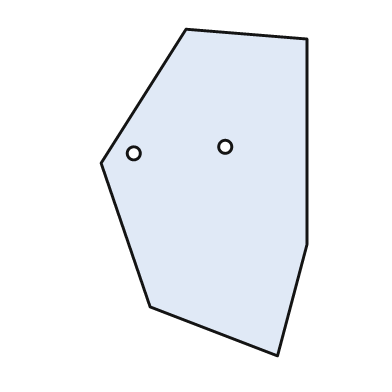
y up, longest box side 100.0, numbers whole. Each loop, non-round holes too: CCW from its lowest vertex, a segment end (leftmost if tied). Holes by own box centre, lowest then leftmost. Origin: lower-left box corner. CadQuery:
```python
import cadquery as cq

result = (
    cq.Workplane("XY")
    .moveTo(54.0, 0.0)
    .lineTo(63.0, 34.0)
    .lineTo(63.0, 97.0)
    .lineTo(26.0, 100.0)
    .lineTo(0.0, 59.0)
    .lineTo(15.0, 15.0)
    .close()
    .moveTo(10.0, 62.0)
    .circle(2.0)
    .moveTo(38.0, 64.0)
    .circle(2.0)
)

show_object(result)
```